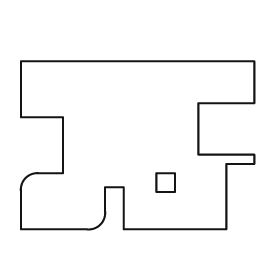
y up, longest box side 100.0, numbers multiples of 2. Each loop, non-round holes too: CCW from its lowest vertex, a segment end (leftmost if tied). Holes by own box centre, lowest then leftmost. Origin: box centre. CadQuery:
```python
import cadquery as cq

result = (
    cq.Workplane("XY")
    .moveTo(-50.0, -36.0)
    .lineTo(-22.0, -36.0)
    .threePointArc((-16.0, -34.0), (-14.0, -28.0))
    .lineTo(-14.0, -18.0)
    .lineTo(-6.0, -18.0)
    .lineTo(-6.0, -36.0)
    .lineTo(38.0, -36.0)
    .lineTo(38.0, -8.0)
    .lineTo(50.0, -8.0)
    .lineTo(50.0, -4.0)
    .lineTo(26.0, -4.0)
    .lineTo(26.0, 18.0)
    .lineTo(50.0, 18.0)
    .lineTo(50.0, 36.0)
    .lineTo(-50.0, 36.0)
    .lineTo(-50.0, 12.0)
    .lineTo(-32.0, 12.0)
    .lineTo(-32.0, -12.0)
    .lineTo(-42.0, -12.0)
    .threePointArc((-48.0, -14.0), (-50.0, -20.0))
    .close()
    .moveTo(8.0, -20.0)
    .lineTo(16.0, -20.0)
    .lineTo(16.0, -12.0)
    .lineTo(8.0, -12.0)
    .close()
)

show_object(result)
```